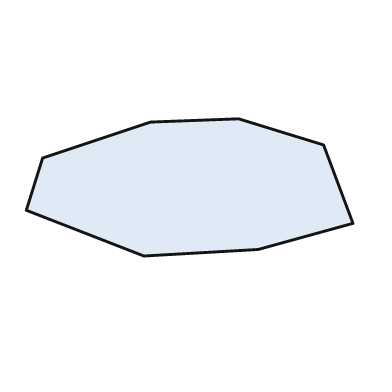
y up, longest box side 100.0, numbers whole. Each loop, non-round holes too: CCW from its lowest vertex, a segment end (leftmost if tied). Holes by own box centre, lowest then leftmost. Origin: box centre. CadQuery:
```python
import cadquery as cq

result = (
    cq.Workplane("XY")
    .moveTo(-14.0, -21.0)
    .lineTo(21.0, -19.0)
    .lineTo(50.0, -11.0)
    .lineTo(41.0, 13.0)
    .lineTo(15.0, 21.0)
    .lineTo(-12.0, 20.0)
    .lineTo(-45.0, 9.0)
    .lineTo(-50.0, -7.0)
    .close()
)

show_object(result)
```